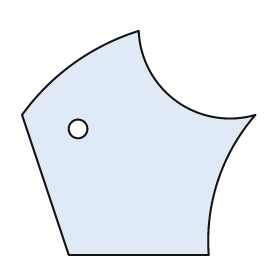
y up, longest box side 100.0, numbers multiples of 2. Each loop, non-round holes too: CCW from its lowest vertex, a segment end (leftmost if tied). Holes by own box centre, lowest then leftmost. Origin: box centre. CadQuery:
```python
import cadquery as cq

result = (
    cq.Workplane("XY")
    .moveTo(-30.0, -48.0)
    .lineTo(30.0, -48.0)
    .threePointArc((34.0, -16.0), (50.0, 12.0))
    .threePointArc((16.0, 18.0), (0.0, 48.0))
    .threePointArc((-28.0, 34.0), (-50.0, 12.0))
    .close()
    .moveTo(-26.0, 6.0)
    .circle(4.0)
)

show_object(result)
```